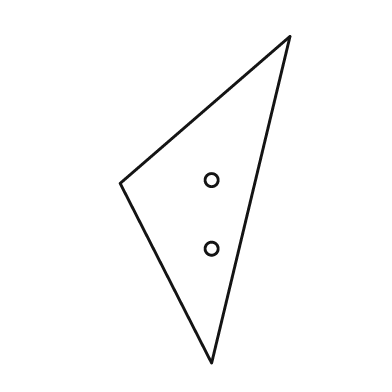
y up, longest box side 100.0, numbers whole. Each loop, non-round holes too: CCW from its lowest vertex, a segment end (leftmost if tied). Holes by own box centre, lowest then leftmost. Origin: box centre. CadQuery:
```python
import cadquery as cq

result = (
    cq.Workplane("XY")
    .moveTo(2.0, -50.0)
    .lineTo(26.0, 50.0)
    .lineTo(-26.0, 5.0)
    .close()
    .moveTo(2.0, -15.0)
    .circle(2.0)
    .moveTo(2.0, 6.0)
    .circle(2.0)
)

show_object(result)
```